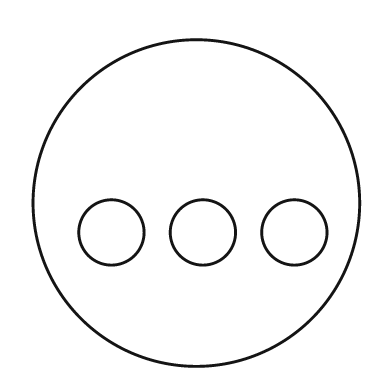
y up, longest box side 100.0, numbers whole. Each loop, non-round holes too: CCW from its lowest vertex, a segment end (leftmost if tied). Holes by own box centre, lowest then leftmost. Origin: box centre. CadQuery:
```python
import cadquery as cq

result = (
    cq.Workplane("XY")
    .moveTo(0.0, 0.0)
    .circle(50.0)
    .moveTo(-26.0, -9.0)
    .circle(10.0)
    .moveTo(2.0, -9.0)
    .circle(10.0)
    .moveTo(30.0, -9.0)
    .circle(10.0)
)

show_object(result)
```